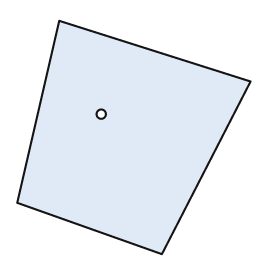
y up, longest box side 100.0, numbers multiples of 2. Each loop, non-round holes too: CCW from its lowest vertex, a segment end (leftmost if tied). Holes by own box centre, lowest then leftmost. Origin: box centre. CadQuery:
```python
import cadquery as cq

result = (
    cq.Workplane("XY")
    .moveTo(12.0, -50.0)
    .lineTo(50.0, 24.0)
    .lineTo(-32.0, 50.0)
    .lineTo(-50.0, -28.0)
    .close()
    .moveTo(-14.0, 10.0)
    .circle(2.0)
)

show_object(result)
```